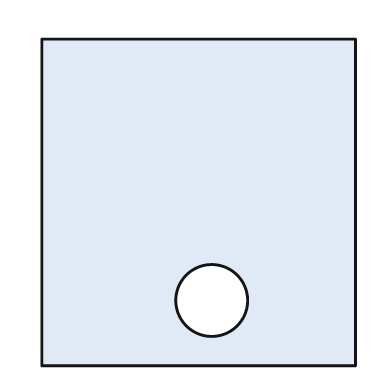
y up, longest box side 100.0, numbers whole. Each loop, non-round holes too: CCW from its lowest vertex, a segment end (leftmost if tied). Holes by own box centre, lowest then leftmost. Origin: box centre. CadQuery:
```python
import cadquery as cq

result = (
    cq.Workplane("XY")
    .moveTo(-48.0, -50.0)
    .lineTo(48.0, -50.0)
    .lineTo(48.0, 50.0)
    .lineTo(-48.0, 50.0)
    .close()
    .moveTo(4.0, -30.0)
    .circle(11.0)
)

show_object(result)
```